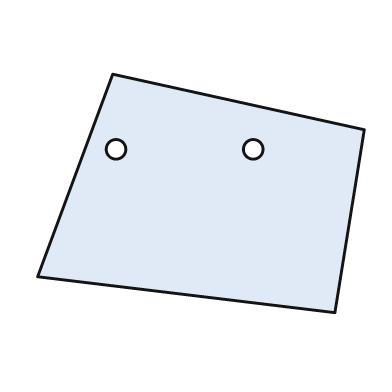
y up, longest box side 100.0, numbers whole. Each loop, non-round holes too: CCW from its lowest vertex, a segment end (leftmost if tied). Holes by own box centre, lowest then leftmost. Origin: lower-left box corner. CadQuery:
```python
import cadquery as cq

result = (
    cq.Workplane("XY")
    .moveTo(91.0, 0.0)
    .lineTo(100.0, 56.0)
    .lineTo(23.0, 73.0)
    .lineTo(0.0, 11.0)
    .close()
    .moveTo(24.0, 50.0)
    .circle(3.0)
    .moveTo(66.0, 50.0)
    .circle(3.0)
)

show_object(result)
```